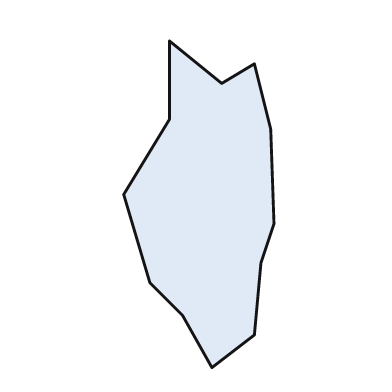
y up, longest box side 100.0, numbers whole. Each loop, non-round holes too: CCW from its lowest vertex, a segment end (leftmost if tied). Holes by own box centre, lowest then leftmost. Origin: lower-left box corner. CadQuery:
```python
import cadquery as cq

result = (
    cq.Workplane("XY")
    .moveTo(27.0, 0.0)
    .lineTo(40.0, 10.0)
    .lineTo(42.0, 32.0)
    .lineTo(46.0, 44.0)
    .lineTo(45.0, 73.0)
    .lineTo(40.0, 93.0)
    .lineTo(30.0, 87.0)
    .lineTo(14.0, 100.0)
    .lineTo(14.0, 76.0)
    .lineTo(0.0, 53.0)
    .lineTo(8.0, 26.0)
    .lineTo(18.0, 16.0)
    .close()
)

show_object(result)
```